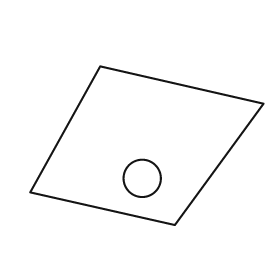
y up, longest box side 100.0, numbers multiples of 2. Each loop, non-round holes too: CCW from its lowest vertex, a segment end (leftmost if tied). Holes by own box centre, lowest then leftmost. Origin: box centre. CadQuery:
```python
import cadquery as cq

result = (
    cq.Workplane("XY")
    .moveTo(12.0, -34.0)
    .lineTo(50.0, 18.0)
    .lineTo(-20.0, 34.0)
    .lineTo(-50.0, -20.0)
    .close()
    .moveTo(-2.0, -14.0)
    .circle(8.0)
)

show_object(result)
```